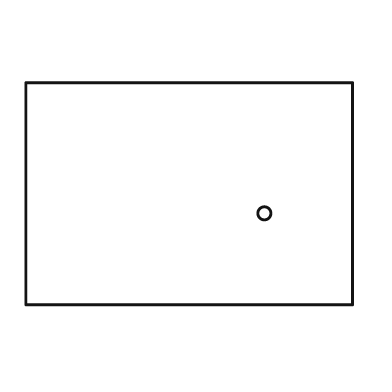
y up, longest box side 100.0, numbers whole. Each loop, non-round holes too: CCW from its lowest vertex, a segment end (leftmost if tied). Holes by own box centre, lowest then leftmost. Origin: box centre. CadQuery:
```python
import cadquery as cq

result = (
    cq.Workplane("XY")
    .moveTo(-50.0, -34.0)
    .lineTo(50.0, -34.0)
    .lineTo(50.0, 34.0)
    .lineTo(-50.0, 34.0)
    .close()
    .moveTo(23.0, -6.0)
    .circle(2.0)
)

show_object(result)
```